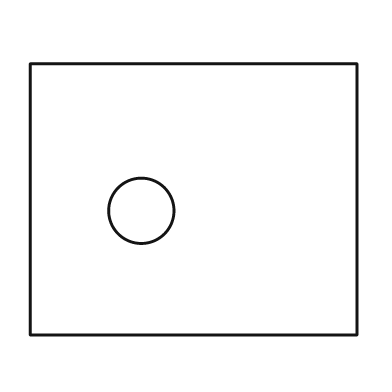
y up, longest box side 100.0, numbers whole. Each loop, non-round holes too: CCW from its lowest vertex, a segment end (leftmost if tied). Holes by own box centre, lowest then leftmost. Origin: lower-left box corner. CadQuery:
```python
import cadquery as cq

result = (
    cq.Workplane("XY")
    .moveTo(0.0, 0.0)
    .lineTo(100.0, 0.0)
    .lineTo(100.0, 83.0)
    .lineTo(0.0, 83.0)
    .close()
    .moveTo(34.0, 38.0)
    .circle(10.0)
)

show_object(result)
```